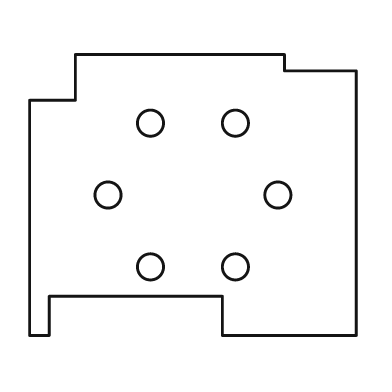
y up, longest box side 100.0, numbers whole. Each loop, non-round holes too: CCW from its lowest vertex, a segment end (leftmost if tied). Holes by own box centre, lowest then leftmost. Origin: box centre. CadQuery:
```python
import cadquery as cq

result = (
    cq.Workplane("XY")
    .moveTo(-50.0, -43.0)
    .lineTo(-44.0, -43.0)
    .lineTo(-44.0, -31.0)
    .lineTo(9.0, -31.0)
    .lineTo(9.0, -43.0)
    .lineTo(50.0, -43.0)
    .lineTo(50.0, 38.0)
    .lineTo(28.0, 38.0)
    .lineTo(28.0, 43.0)
    .lineTo(-36.0, 43.0)
    .lineTo(-36.0, 29.0)
    .lineTo(-50.0, 29.0)
    .close()
    .moveTo(-13.0, -22.0)
    .circle(4.0)
    .moveTo(13.0, -22.0)
    .circle(4.0)
    .moveTo(-26.0, 0.0)
    .circle(4.0)
    .moveTo(26.0, 0.0)
    .circle(4.0)
    .moveTo(-13.0, 22.0)
    .circle(4.0)
    .moveTo(13.0, 22.0)
    .circle(4.0)
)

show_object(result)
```